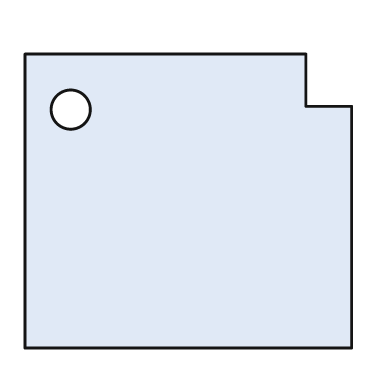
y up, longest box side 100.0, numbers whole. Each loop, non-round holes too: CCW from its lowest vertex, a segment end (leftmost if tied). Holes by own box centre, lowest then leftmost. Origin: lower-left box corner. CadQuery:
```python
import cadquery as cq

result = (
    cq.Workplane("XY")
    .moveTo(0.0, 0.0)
    .lineTo(100.0, 0.0)
    .lineTo(100.0, 74.0)
    .lineTo(86.0, 74.0)
    .lineTo(86.0, 90.0)
    .lineTo(0.0, 90.0)
    .close()
    .moveTo(14.0, 73.0)
    .circle(6.0)
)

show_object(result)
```